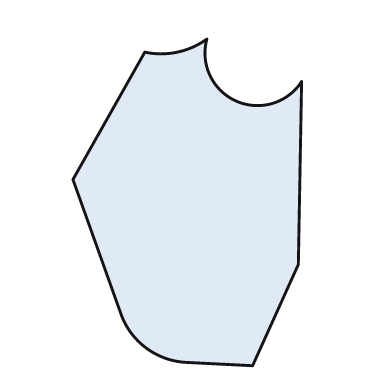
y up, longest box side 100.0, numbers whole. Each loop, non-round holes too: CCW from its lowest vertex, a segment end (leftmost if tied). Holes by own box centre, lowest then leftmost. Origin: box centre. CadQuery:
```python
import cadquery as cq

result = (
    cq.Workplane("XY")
    .moveTo(20.0, -50.0)
    .lineTo(34.0, -19.0)
    .lineTo(35.0, 37.0)
    .threePointArc((15.0, 31.0), (6.0, 50.0))
    .threePointArc((-3.0, 46.0), (-13.0, 46.0))
    .lineTo(-35.0, 7.0)
    .lineTo(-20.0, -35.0)
    .threePointArc((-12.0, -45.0), (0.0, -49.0))
    .close()
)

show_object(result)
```